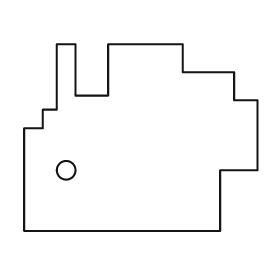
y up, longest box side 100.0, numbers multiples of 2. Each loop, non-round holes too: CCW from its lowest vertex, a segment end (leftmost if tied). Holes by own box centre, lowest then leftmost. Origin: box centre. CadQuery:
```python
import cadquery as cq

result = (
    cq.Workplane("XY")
    .moveTo(-50.0, -40.0)
    .lineTo(34.0, -40.0)
    .lineTo(34.0, -14.0)
    .lineTo(50.0, -14.0)
    .lineTo(50.0, 16.0)
    .lineTo(40.0, 16.0)
    .lineTo(40.0, 28.0)
    .lineTo(18.0, 28.0)
    .lineTo(18.0, 40.0)
    .lineTo(-14.0, 40.0)
    .lineTo(-14.0, 18.0)
    .lineTo(-28.0, 18.0)
    .lineTo(-28.0, 40.0)
    .lineTo(-36.0, 40.0)
    .lineTo(-36.0, 12.0)
    .lineTo(-42.0, 12.0)
    .lineTo(-42.0, 4.0)
    .lineTo(-50.0, 4.0)
    .close()
    .moveTo(-32.0, -14.0)
    .circle(4.0)
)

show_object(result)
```